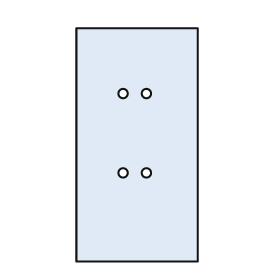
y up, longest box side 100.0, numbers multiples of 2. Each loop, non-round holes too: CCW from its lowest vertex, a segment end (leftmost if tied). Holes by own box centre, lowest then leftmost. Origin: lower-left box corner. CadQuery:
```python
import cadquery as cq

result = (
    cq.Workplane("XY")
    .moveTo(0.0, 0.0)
    .lineTo(52.0, 0.0)
    .lineTo(52.0, 100.0)
    .lineTo(0.0, 100.0)
    .close()
    .moveTo(20.0, 38.0)
    .circle(2.0)
    .moveTo(30.0, 38.0)
    .circle(2.0)
    .moveTo(20.0, 72.0)
    .circle(2.0)
    .moveTo(30.0, 72.0)
    .circle(2.0)
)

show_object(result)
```